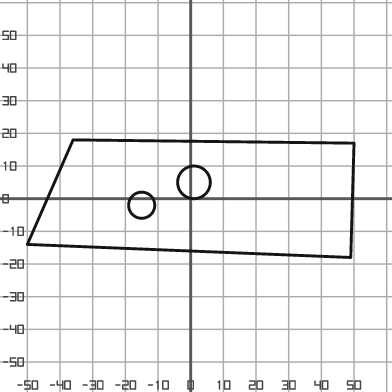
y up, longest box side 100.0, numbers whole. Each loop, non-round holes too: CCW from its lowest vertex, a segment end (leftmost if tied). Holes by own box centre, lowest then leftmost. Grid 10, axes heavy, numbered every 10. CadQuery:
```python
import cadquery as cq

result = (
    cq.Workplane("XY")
    .moveTo(49.0, -18.0)
    .lineTo(50.0, 17.0)
    .lineTo(-36.0, 18.0)
    .lineTo(-50.0, -14.0)
    .close()
    .moveTo(-15.0, -2.0)
    .circle(4.0)
    .moveTo(1.0, 5.0)
    .circle(5.0)
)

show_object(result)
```